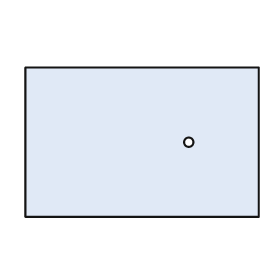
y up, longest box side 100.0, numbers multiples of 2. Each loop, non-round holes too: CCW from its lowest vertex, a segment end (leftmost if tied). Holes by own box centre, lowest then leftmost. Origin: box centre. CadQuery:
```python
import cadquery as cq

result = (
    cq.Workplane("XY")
    .moveTo(-50.0, -32.0)
    .lineTo(50.0, -32.0)
    .lineTo(50.0, 32.0)
    .lineTo(-50.0, 32.0)
    .close()
    .moveTo(20.0, 0.0)
    .circle(2.0)
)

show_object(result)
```